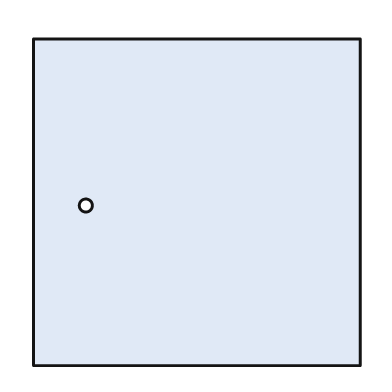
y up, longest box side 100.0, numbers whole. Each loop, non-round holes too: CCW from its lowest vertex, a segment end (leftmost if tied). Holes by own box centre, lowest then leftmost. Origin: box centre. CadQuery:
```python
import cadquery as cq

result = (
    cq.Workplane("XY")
    .moveTo(-50.0, -50.0)
    .lineTo(50.0, -50.0)
    .lineTo(50.0, 50.0)
    .lineTo(-50.0, 50.0)
    .close()
    .moveTo(-34.0, -1.0)
    .circle(2.0)
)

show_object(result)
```